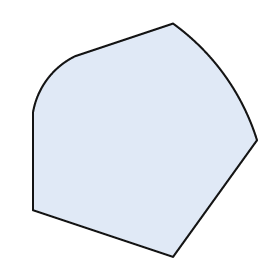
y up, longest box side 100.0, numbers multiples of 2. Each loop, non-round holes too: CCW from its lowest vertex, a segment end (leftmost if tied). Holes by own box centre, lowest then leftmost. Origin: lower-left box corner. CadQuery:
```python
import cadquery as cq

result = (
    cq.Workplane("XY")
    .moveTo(60.0, 0.0)
    .lineTo(96.0, 50.0)
    .threePointArc((82.0, 78.0), (60.0, 100.0))
    .lineTo(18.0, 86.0)
    .threePointArc((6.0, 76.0), (0.0, 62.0))
    .lineTo(0.0, 20.0)
    .close()
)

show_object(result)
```